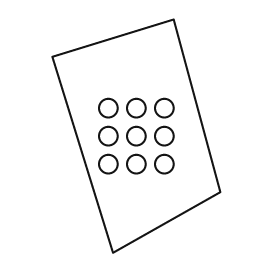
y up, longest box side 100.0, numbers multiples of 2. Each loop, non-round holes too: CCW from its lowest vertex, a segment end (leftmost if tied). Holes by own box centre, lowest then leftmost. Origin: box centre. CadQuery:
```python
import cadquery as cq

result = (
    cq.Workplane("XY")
    .moveTo(-10.0, -50.0)
    .lineTo(36.0, -24.0)
    .lineTo(16.0, 50.0)
    .lineTo(-36.0, 34.0)
    .close()
    .moveTo(-12.0, -12.0)
    .circle(4.0)
    .moveTo(0.0, -12.0)
    .circle(4.0)
    .moveTo(12.0, -12.0)
    .circle(4.0)
    .moveTo(-12.0, 0.0)
    .circle(4.0)
    .moveTo(0.0, 0.0)
    .circle(4.0)
    .moveTo(12.0, 0.0)
    .circle(4.0)
    .moveTo(-12.0, 12.0)
    .circle(4.0)
    .moveTo(0.0, 12.0)
    .circle(4.0)
    .moveTo(12.0, 12.0)
    .circle(4.0)
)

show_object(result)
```